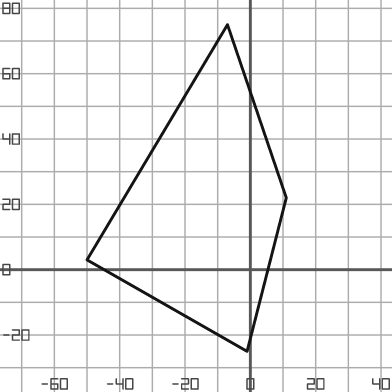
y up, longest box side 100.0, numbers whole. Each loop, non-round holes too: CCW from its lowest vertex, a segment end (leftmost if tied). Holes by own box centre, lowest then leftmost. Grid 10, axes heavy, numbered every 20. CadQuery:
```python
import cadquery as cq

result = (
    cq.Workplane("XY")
    .moveTo(-1.0, -25.0)
    .lineTo(11.0, 22.0)
    .lineTo(-7.0, 75.0)
    .lineTo(-50.0, 3.0)
    .close()
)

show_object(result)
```